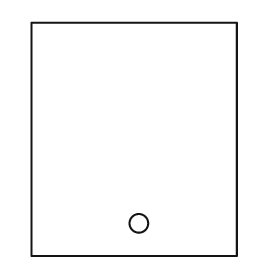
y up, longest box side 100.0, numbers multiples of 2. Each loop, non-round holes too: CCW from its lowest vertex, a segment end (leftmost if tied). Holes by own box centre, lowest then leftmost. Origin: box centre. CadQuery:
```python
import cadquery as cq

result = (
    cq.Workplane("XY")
    .moveTo(-44.0, -50.0)
    .lineTo(44.0, -50.0)
    .lineTo(44.0, 50.0)
    .lineTo(-44.0, 50.0)
    .close()
    .moveTo(2.0, -36.0)
    .circle(4.0)
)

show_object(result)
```